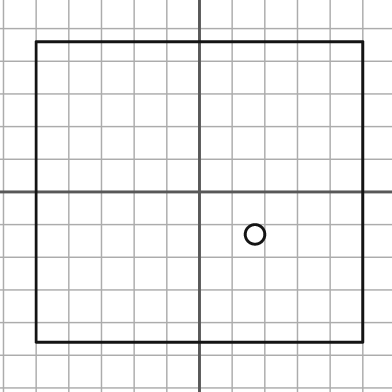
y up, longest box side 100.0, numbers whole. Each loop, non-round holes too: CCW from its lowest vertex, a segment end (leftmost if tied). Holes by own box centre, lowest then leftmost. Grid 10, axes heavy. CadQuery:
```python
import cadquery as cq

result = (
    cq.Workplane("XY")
    .moveTo(-50.0, -46.0)
    .lineTo(50.0, -46.0)
    .lineTo(50.0, 46.0)
    .lineTo(-50.0, 46.0)
    .close()
    .moveTo(17.0, -13.0)
    .circle(3.0)
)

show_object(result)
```